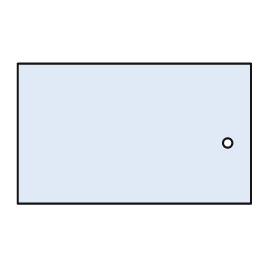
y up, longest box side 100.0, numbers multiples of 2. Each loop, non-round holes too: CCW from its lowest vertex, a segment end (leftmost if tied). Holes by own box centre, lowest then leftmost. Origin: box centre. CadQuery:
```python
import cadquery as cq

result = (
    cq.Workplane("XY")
    .moveTo(-50.0, -30.0)
    .lineTo(50.0, -30.0)
    .lineTo(50.0, 30.0)
    .lineTo(-50.0, 30.0)
    .close()
    .moveTo(40.0, -4.0)
    .circle(2.0)
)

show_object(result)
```